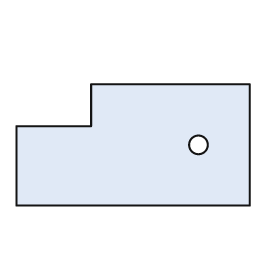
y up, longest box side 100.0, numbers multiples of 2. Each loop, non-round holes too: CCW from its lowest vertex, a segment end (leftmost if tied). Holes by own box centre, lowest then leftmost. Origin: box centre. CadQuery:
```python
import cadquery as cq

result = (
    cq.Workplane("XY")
    .moveTo(-50.0, -26.0)
    .lineTo(50.0, -26.0)
    .lineTo(50.0, 26.0)
    .lineTo(-18.0, 26.0)
    .lineTo(-18.0, 8.0)
    .lineTo(-50.0, 8.0)
    .close()
    .moveTo(28.0, 0.0)
    .circle(4.0)
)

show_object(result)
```